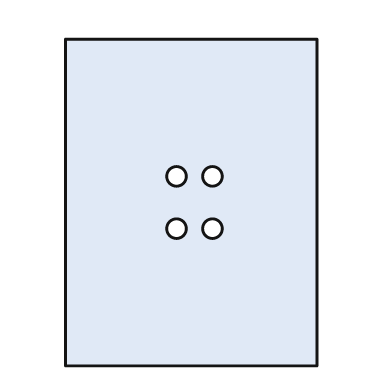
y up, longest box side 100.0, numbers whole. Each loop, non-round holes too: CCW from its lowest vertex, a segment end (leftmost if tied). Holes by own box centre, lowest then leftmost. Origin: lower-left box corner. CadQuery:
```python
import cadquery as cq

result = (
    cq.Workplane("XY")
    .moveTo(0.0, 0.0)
    .lineTo(77.0, 0.0)
    .lineTo(77.0, 100.0)
    .lineTo(0.0, 100.0)
    .close()
    .moveTo(34.0, 42.0)
    .circle(3.0)
    .moveTo(45.0, 42.0)
    .circle(3.0)
    .moveTo(34.0, 58.0)
    .circle(3.0)
    .moveTo(45.0, 58.0)
    .circle(3.0)
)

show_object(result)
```